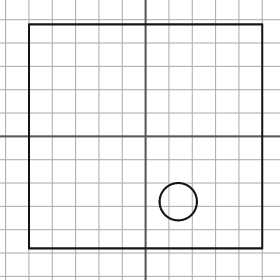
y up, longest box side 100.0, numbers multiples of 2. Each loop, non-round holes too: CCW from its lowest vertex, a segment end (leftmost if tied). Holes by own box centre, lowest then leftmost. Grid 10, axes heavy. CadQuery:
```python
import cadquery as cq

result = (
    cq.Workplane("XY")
    .moveTo(-50.0, -48.0)
    .lineTo(50.0, -48.0)
    .lineTo(50.0, 48.0)
    .lineTo(-50.0, 48.0)
    .close()
    .moveTo(14.0, -28.0)
    .circle(8.0)
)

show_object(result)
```